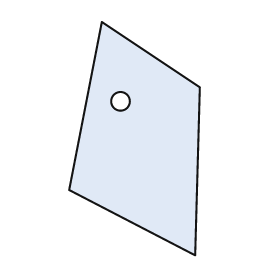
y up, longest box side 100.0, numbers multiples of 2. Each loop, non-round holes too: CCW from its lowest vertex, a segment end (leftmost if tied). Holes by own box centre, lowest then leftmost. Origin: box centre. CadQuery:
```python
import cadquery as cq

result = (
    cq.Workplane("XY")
    .moveTo(26.0, -50.0)
    .lineTo(28.0, 22.0)
    .lineTo(-14.0, 50.0)
    .lineTo(-28.0, -22.0)
    .close()
    .moveTo(-6.0, 16.0)
    .circle(4.0)
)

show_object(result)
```